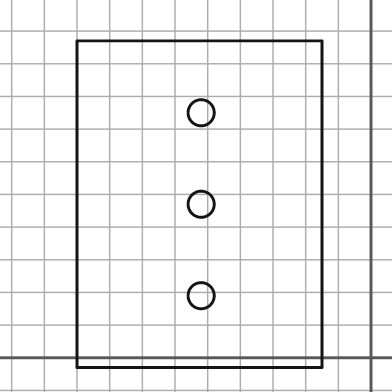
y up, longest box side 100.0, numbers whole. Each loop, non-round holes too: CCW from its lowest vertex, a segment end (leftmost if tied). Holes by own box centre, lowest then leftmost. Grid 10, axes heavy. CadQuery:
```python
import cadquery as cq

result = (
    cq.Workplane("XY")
    .moveTo(-90.0, -3.0)
    .lineTo(-15.0, -3.0)
    .lineTo(-15.0, 97.0)
    .lineTo(-90.0, 97.0)
    .close()
    .moveTo(-52.0, 19.0)
    .circle(4.0)
    .moveTo(-52.0, 47.0)
    .circle(4.0)
    .moveTo(-52.0, 75.0)
    .circle(4.0)
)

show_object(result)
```